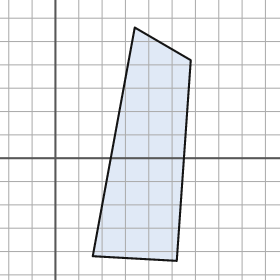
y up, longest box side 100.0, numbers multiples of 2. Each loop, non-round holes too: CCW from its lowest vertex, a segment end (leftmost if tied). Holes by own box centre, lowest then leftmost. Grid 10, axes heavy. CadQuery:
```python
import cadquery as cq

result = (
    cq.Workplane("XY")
    .moveTo(52.0, -44.0)
    .lineTo(58.0, 42.0)
    .lineTo(34.0, 56.0)
    .lineTo(16.0, -42.0)
    .close()
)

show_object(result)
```